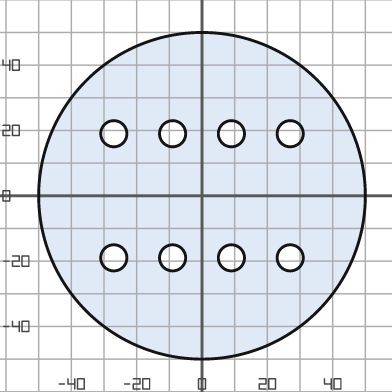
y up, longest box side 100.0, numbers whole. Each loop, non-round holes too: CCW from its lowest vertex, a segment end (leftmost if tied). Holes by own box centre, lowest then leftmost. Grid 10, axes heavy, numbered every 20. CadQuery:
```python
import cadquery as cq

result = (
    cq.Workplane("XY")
    .moveTo(0.0, 0.0)
    .circle(50.0)
    .moveTo(-27.0, -19.0)
    .circle(4.0)
    .moveTo(-9.0, -19.0)
    .circle(4.0)
    .moveTo(9.0, -19.0)
    .circle(4.0)
    .moveTo(27.0, -19.0)
    .circle(4.0)
    .moveTo(-27.0, 19.0)
    .circle(4.0)
    .moveTo(-9.0, 19.0)
    .circle(4.0)
    .moveTo(9.0, 19.0)
    .circle(4.0)
    .moveTo(27.0, 19.0)
    .circle(4.0)
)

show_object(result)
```